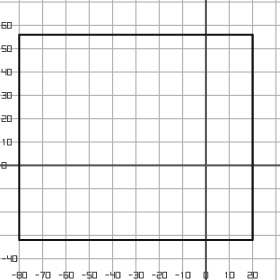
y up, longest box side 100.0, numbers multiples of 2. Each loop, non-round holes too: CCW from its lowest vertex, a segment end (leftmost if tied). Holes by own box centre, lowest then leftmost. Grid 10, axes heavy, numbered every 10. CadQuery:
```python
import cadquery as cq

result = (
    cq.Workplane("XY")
    .moveTo(-80.0, -32.0)
    .lineTo(20.0, -32.0)
    .lineTo(20.0, 56.0)
    .lineTo(-80.0, 56.0)
    .close()
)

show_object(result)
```